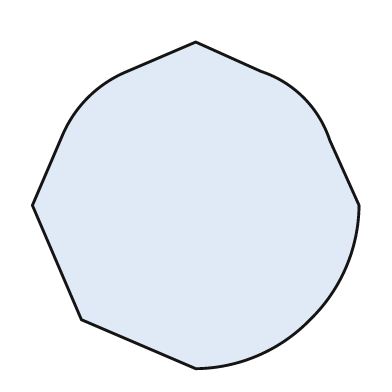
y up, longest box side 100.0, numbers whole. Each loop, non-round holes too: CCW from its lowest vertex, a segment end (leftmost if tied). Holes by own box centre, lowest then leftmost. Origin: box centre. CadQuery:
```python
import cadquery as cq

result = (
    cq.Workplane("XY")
    .moveTo(0.0, -50.0)
    .threePointArc((19.0, -46.0), (35.0, -35.0))
    .threePointArc((46.0, -19.0), (50.0, 0.0))
    .lineTo(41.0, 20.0)
    .threePointArc((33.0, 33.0), (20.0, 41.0))
    .lineTo(0.0, 50.0)
    .lineTo(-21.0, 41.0)
    .threePointArc((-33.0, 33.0), (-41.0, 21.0))
    .lineTo(-50.0, 0.0)
    .lineTo(-35.0, -35.0)
    .close()
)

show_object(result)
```